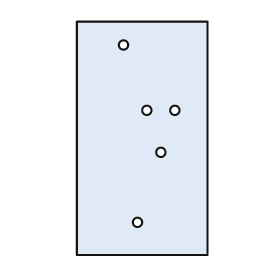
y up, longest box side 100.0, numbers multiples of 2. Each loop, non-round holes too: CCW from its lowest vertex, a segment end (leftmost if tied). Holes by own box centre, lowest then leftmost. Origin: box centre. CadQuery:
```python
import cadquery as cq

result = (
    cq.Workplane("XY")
    .moveTo(-28.0, -50.0)
    .lineTo(28.0, -50.0)
    .lineTo(28.0, 50.0)
    .lineTo(-28.0, 50.0)
    .close()
    .moveTo(-2.0, -36.0)
    .circle(2.0)
    .moveTo(8.0, -6.0)
    .circle(2.0)
    .moveTo(2.0, 12.0)
    .circle(2.0)
    .moveTo(14.0, 12.0)
    .circle(2.0)
    .moveTo(-8.0, 40.0)
    .circle(2.0)
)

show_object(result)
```